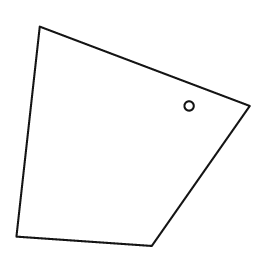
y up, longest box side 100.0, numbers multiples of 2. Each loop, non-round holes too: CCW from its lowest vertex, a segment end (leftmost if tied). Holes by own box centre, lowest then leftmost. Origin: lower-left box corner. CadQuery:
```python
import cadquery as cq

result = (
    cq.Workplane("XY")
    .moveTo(58.0, 0.0)
    .lineTo(100.0, 60.0)
    .lineTo(10.0, 94.0)
    .lineTo(0.0, 4.0)
    .close()
    .moveTo(74.0, 60.0)
    .circle(2.0)
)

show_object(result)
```